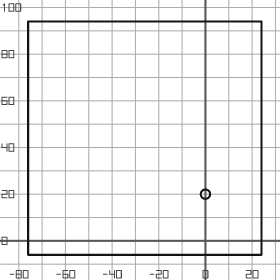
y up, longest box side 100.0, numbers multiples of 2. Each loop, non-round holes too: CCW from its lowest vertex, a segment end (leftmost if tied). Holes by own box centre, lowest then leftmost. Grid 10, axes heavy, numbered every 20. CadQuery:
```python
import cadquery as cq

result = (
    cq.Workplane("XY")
    .moveTo(-76.0, -6.0)
    .lineTo(24.0, -6.0)
    .lineTo(24.0, 94.0)
    .lineTo(-76.0, 94.0)
    .close()
    .moveTo(0.0, 20.0)
    .circle(2.0)
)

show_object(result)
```